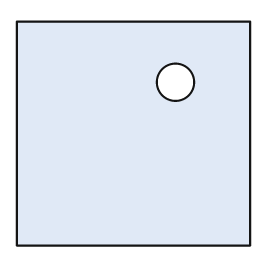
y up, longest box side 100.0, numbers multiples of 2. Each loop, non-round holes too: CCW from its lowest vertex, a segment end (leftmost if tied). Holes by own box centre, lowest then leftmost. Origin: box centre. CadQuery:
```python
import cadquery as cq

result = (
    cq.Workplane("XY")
    .moveTo(-50.0, -48.0)
    .lineTo(50.0, -48.0)
    .lineTo(50.0, 48.0)
    .lineTo(-50.0, 48.0)
    .close()
    .moveTo(18.0, 22.0)
    .circle(8.0)
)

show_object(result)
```